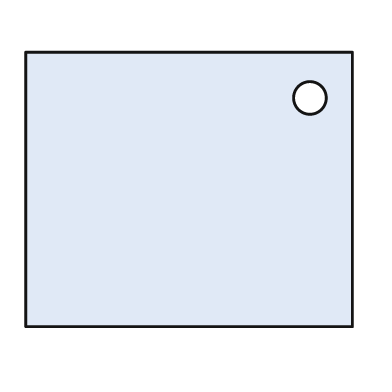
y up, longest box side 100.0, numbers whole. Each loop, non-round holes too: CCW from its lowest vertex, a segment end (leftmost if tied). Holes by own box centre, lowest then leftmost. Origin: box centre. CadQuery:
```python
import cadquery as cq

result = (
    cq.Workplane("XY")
    .moveTo(-50.0, -42.0)
    .lineTo(50.0, -42.0)
    .lineTo(50.0, 42.0)
    .lineTo(-50.0, 42.0)
    .close()
    .moveTo(37.0, 28.0)
    .circle(5.0)
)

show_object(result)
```